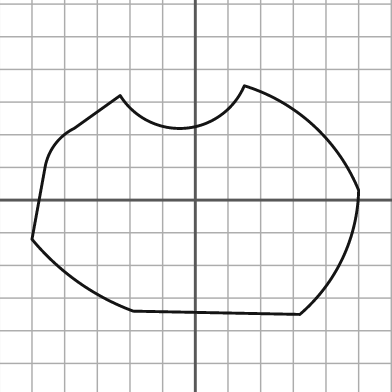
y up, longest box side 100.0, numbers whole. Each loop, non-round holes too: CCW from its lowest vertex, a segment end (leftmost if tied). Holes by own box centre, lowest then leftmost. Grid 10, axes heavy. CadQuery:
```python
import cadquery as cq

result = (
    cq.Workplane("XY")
    .moveTo(32.0, -35.0)
    .threePointArc((45.0, -18.0), (50.0, 3.0))
    .threePointArc((36.0, 23.0), (15.0, 35.0))
    .threePointArc((-3.0, 22.0), (-23.0, 32.0))
    .lineTo(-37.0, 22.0)
    .threePointArc((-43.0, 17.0), (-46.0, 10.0))
    .lineTo(-50.0, -12.0)
    .threePointArc((-36.0, -25.0), (-19.0, -34.0))
    .close()
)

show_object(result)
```